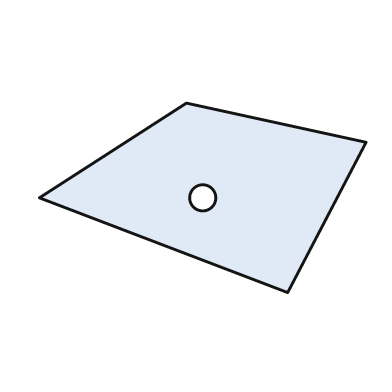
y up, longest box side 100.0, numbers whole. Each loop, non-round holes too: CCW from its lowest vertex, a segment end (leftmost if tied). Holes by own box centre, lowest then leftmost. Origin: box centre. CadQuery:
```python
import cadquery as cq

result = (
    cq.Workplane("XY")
    .moveTo(26.0, -29.0)
    .lineTo(50.0, 17.0)
    .lineTo(-5.0, 29.0)
    .lineTo(-50.0, 0.0)
    .close()
    .moveTo(0.0, 0.0)
    .circle(4.0)
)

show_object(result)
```